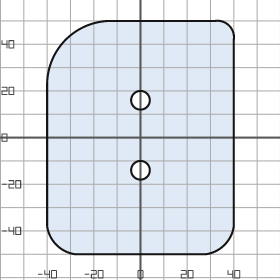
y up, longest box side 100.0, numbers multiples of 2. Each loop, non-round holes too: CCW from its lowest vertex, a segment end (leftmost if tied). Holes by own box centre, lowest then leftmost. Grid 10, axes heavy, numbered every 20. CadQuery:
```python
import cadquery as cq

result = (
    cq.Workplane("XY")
    .moveTo(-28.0, -50.0)
    .lineTo(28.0, -50.0)
    .threePointArc((36.0, -46.0), (40.0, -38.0))
    .lineTo(40.0, 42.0)
    .threePointArc((38.0, 48.0), (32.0, 50.0))
    .lineTo(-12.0, 50.0)
    .threePointArc((-32.0, 42.0), (-40.0, 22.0))
    .lineTo(-40.0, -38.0)
    .threePointArc((-36.0, -46.0), (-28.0, -50.0))
    .close()
    .moveTo(0.0, -14.0)
    .circle(4.0)
    .moveTo(0.0, 16.0)
    .circle(4.0)
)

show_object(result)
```